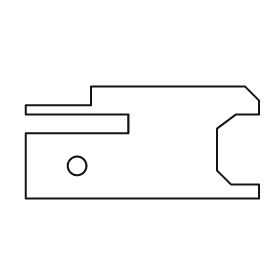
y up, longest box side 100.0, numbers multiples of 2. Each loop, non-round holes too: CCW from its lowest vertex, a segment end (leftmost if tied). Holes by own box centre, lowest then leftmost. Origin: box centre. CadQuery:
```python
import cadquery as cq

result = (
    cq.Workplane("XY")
    .moveTo(-50.0, -24.0)
    .lineTo(50.0, -24.0)
    .lineTo(50.0, -18.0)
    .lineTo(38.0, -18.0)
    .lineTo(32.0, -12.0)
    .lineTo(32.0, 6.0)
    .lineTo(40.0, 12.0)
    .lineTo(50.0, 12.0)
    .lineTo(50.0, 18.0)
    .lineTo(44.0, 24.0)
    .lineTo(-22.0, 24.0)
    .lineTo(-22.0, 16.0)
    .lineTo(-50.0, 16.0)
    .lineTo(-50.0, 12.0)
    .lineTo(-6.0, 12.0)
    .lineTo(-6.0, 4.0)
    .lineTo(-50.0, 4.0)
    .close()
    .moveTo(-28.0, -10.0)
    .circle(4.0)
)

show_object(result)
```